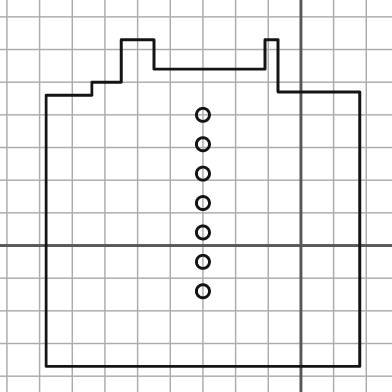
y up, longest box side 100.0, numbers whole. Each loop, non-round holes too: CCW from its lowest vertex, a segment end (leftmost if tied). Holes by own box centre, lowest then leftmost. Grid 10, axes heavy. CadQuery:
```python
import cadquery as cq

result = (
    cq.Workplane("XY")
    .moveTo(-78.0, -37.0)
    .lineTo(18.0, -37.0)
    .lineTo(18.0, 47.0)
    .lineTo(-7.0, 47.0)
    .lineTo(-7.0, 63.0)
    .lineTo(-11.0, 63.0)
    .lineTo(-11.0, 54.0)
    .lineTo(-45.0, 54.0)
    .lineTo(-45.0, 63.0)
    .lineTo(-55.0, 63.0)
    .lineTo(-55.0, 50.0)
    .lineTo(-64.0, 50.0)
    .lineTo(-64.0, 46.0)
    .lineTo(-78.0, 46.0)
    .close()
    .moveTo(-30.0, -14.0)
    .circle(2.0)
    .moveTo(-30.0, -5.0)
    .circle(2.0)
    .moveTo(-30.0, 4.0)
    .circle(2.0)
    .moveTo(-30.0, 13.0)
    .circle(2.0)
    .moveTo(-30.0, 22.0)
    .circle(2.0)
    .moveTo(-30.0, 31.0)
    .circle(2.0)
    .moveTo(-30.0, 40.0)
    .circle(2.0)
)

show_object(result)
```